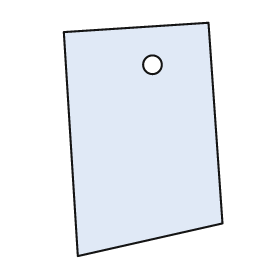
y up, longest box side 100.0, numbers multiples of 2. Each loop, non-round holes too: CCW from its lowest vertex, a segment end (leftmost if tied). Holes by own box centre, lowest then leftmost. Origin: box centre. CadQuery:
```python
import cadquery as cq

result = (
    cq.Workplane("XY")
    .moveTo(-28.0, -50.0)
    .lineTo(34.0, -36.0)
    .lineTo(28.0, 50.0)
    .lineTo(-34.0, 46.0)
    .close()
    .moveTo(4.0, 32.0)
    .circle(4.0)
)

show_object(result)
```